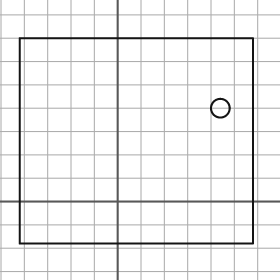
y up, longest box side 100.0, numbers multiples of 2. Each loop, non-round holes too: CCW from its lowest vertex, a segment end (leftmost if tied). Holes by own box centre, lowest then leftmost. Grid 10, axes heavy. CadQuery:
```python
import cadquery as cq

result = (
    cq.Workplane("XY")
    .moveTo(-42.0, -18.0)
    .lineTo(58.0, -18.0)
    .lineTo(58.0, 70.0)
    .lineTo(-42.0, 70.0)
    .close()
    .moveTo(44.0, 40.0)
    .circle(4.0)
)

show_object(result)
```